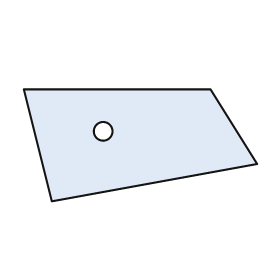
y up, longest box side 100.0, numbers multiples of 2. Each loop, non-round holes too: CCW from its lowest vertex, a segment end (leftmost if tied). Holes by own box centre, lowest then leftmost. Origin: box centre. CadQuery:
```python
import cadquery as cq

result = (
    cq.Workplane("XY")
    .moveTo(-38.0, -24.0)
    .lineTo(50.0, -8.0)
    .lineTo(30.0, 24.0)
    .lineTo(-50.0, 24.0)
    .close()
    .moveTo(-16.0, 6.0)
    .circle(4.0)
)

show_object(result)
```